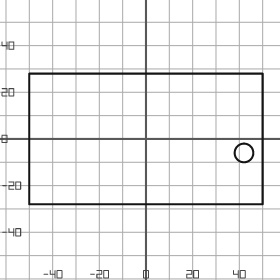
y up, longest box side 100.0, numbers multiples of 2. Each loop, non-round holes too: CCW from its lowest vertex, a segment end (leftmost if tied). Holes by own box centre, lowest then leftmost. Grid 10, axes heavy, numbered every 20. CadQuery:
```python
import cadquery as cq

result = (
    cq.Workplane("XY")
    .moveTo(-50.0, -28.0)
    .lineTo(50.0, -28.0)
    .lineTo(50.0, 28.0)
    .lineTo(-50.0, 28.0)
    .close()
    .moveTo(42.0, -6.0)
    .circle(4.0)
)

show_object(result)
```